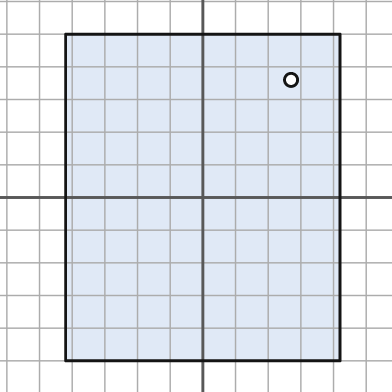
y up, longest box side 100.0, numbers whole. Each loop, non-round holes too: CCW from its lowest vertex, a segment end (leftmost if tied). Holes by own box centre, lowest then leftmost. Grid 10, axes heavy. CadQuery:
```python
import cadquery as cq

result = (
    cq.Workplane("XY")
    .moveTo(-42.0, -50.0)
    .lineTo(42.0, -50.0)
    .lineTo(42.0, 50.0)
    .lineTo(-42.0, 50.0)
    .close()
    .moveTo(27.0, 36.0)
    .circle(2.0)
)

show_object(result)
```